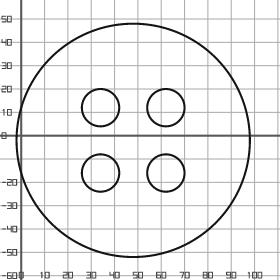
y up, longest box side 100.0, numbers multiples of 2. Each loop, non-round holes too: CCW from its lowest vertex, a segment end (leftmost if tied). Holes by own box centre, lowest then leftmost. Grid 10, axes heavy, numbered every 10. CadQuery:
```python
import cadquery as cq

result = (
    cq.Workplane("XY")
    .moveTo(48.0, -2.0)
    .circle(50.0)
    .moveTo(34.0, -16.0)
    .circle(8.0)
    .moveTo(62.0, -16.0)
    .circle(8.0)
    .moveTo(34.0, 12.0)
    .circle(8.0)
    .moveTo(62.0, 12.0)
    .circle(8.0)
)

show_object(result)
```